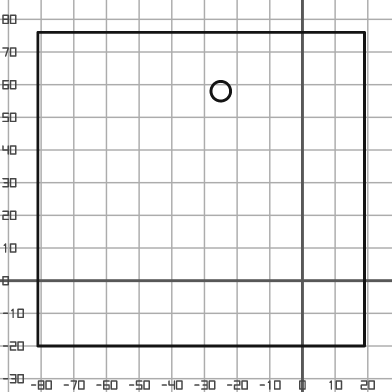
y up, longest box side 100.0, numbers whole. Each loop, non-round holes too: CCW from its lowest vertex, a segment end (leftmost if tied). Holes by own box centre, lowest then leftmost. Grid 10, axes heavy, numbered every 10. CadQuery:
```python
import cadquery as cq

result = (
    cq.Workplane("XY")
    .moveTo(-81.0, -20.0)
    .lineTo(19.0, -20.0)
    .lineTo(19.0, 76.0)
    .lineTo(-81.0, 76.0)
    .close()
    .moveTo(-25.0, 58.0)
    .circle(3.0)
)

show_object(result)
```